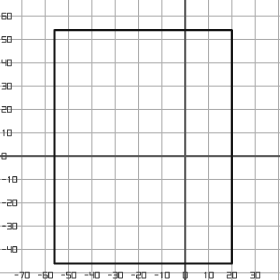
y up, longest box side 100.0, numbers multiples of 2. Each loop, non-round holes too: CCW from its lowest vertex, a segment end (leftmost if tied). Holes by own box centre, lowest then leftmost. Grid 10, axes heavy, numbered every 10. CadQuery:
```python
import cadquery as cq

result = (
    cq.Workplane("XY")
    .moveTo(-56.0, -46.0)
    .lineTo(20.0, -46.0)
    .lineTo(20.0, 54.0)
    .lineTo(-56.0, 54.0)
    .close()
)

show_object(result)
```